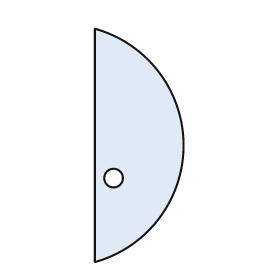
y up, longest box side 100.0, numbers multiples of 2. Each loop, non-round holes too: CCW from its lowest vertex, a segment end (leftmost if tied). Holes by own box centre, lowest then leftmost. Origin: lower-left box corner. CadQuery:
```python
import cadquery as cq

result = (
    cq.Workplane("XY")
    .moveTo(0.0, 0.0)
    .threePointArc((38.0, 50.0), (0.0, 100.0))
    .close()
    .moveTo(8.0, 36.0)
    .circle(4.0)
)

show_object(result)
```